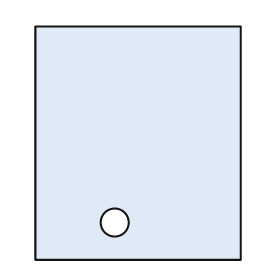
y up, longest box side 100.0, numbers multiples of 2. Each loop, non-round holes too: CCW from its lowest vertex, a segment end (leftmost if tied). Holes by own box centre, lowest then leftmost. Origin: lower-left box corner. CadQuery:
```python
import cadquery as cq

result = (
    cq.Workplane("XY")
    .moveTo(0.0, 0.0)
    .lineTo(88.0, 0.0)
    .lineTo(88.0, 100.0)
    .lineTo(0.0, 100.0)
    .close()
    .moveTo(34.0, 16.0)
    .circle(6.0)
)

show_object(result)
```